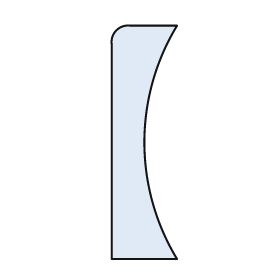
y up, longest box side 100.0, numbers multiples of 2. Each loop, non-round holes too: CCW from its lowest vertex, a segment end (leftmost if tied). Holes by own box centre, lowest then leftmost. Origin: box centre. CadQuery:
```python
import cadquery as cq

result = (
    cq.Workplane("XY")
    .moveTo(-14.0, -50.0)
    .lineTo(14.0, -50.0)
    .threePointArc((0.0, 0.0), (14.0, 50.0))
    .lineTo(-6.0, 50.0)
    .threePointArc((-12.0, 48.0), (-14.0, 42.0))
    .close()
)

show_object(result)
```